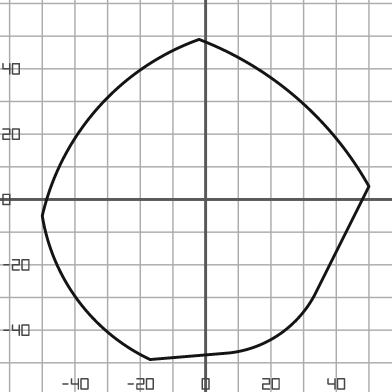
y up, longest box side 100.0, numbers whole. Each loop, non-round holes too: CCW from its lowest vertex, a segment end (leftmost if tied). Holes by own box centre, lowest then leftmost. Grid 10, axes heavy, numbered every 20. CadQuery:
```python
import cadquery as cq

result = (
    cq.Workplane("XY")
    .moveTo(-17.0, -49.0)
    .lineTo(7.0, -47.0)
    .threePointArc((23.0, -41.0), (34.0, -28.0))
    .lineTo(50.0, 4.0)
    .threePointArc((28.0, 31.0), (-2.0, 49.0))
    .threePointArc((-33.0, 28.0), (-50.0, -5.0))
    .threePointArc((-39.0, -31.0), (-17.0, -49.0))
    .close()
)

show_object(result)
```